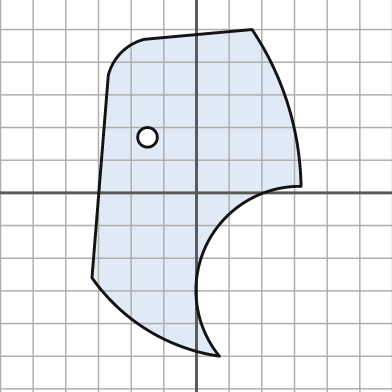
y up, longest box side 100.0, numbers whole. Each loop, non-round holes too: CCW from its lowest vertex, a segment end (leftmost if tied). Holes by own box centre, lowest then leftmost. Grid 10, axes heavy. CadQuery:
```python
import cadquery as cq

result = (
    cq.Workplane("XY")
    .moveTo(7.0, -50.0)
    .threePointArc((3.0, -16.0), (32.0, 2.0))
    .threePointArc((28.0, 27.0), (17.0, 50.0))
    .lineTo(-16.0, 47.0)
    .threePointArc((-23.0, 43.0), (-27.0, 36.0))
    .lineTo(-32.0, -26.0)
    .threePointArc((-15.0, -42.0), (7.0, -50.0))
    .close()
    .moveTo(-15.0, 17.0)
    .circle(3.0)
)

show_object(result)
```